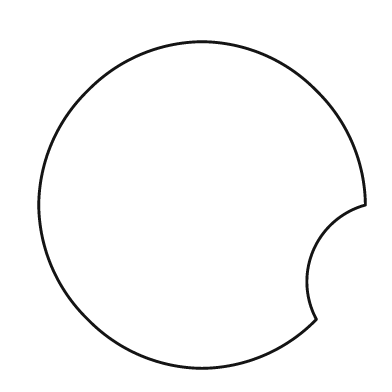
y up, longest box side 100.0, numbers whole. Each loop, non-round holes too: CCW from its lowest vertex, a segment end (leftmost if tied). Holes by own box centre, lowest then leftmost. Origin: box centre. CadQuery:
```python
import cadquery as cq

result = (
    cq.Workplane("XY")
    .moveTo(0.0, -50.0)
    .threePointArc((19.0, -46.0), (35.0, -35.0))
    .threePointArc((34.0, -14.0), (50.0, 0.0))
    .threePointArc((46.0, 19.0), (35.0, 35.0))
    .threePointArc((19.0, 46.0), (0.0, 50.0))
    .threePointArc((-19.0, 46.0), (-35.0, 35.0))
    .threePointArc((-46.0, 19.0), (-50.0, 0.0))
    .threePointArc((-46.0, -19.0), (-35.0, -35.0))
    .threePointArc((-19.0, -46.0), (0.0, -50.0))
    .close()
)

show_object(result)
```